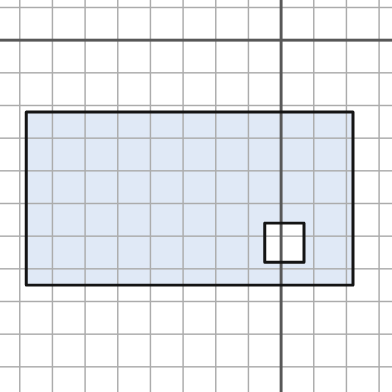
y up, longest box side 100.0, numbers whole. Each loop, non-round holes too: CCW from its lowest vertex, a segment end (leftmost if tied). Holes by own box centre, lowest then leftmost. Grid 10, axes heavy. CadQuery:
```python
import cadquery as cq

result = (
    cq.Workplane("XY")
    .moveTo(-78.0, -75.0)
    .lineTo(22.0, -75.0)
    .lineTo(22.0, -22.0)
    .lineTo(-78.0, -22.0)
    .close()
    .moveTo(-5.0, -68.0)
    .lineTo(7.0, -68.0)
    .lineTo(7.0, -56.0)
    .lineTo(-5.0, -56.0)
    .close()
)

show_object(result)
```